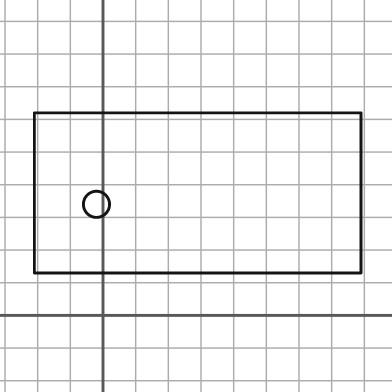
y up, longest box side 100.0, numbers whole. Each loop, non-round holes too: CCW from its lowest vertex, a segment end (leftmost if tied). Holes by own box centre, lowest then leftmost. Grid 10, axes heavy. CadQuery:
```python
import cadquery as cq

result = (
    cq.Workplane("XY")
    .moveTo(-21.0, 13.0)
    .lineTo(79.0, 13.0)
    .lineTo(79.0, 62.0)
    .lineTo(-21.0, 62.0)
    .close()
    .moveTo(-2.0, 34.0)
    .circle(4.0)
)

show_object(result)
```